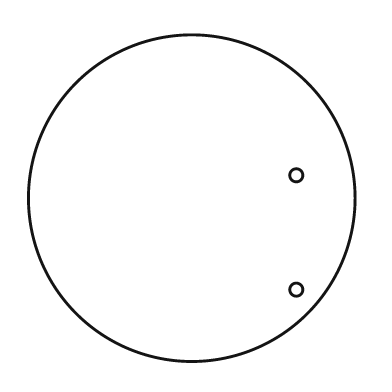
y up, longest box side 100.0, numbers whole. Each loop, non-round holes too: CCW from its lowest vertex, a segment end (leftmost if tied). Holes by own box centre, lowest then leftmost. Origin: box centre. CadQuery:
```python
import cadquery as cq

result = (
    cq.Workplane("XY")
    .moveTo(0.0, 0.0)
    .circle(50.0)
    .moveTo(32.0, -28.0)
    .circle(2.0)
    .moveTo(32.0, 7.0)
    .circle(2.0)
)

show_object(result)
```